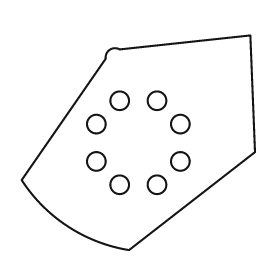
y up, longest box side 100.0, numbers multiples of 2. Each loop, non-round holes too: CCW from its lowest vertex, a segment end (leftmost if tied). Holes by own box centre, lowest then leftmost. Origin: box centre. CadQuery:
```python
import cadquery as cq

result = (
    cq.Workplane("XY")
    .moveTo(-4.0, -46.0)
    .lineTo(50.0, -4.0)
    .lineTo(48.0, 46.0)
    .lineTo(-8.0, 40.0)
    .threePointArc((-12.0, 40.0), (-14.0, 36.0))
    .lineTo(-50.0, -16.0)
    .threePointArc((-30.0, -36.0), (-4.0, -46.0))
    .close()
    .moveTo(-8.0, -18.0)
    .circle(4.0)
    .moveTo(8.0, -18.0)
    .circle(4.0)
    .moveTo(-18.0, -8.0)
    .circle(4.0)
    .moveTo(18.0, -8.0)
    .circle(4.0)
    .moveTo(-18.0, 8.0)
    .circle(4.0)
    .moveTo(18.0, 8.0)
    .circle(4.0)
    .moveTo(-8.0, 18.0)
    .circle(4.0)
    .moveTo(8.0, 18.0)
    .circle(4.0)
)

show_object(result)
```